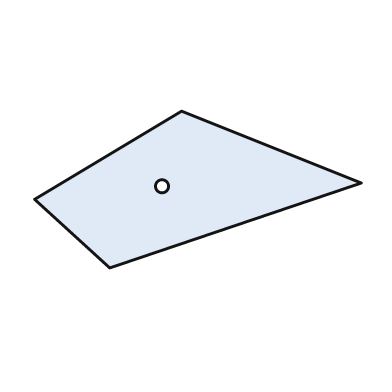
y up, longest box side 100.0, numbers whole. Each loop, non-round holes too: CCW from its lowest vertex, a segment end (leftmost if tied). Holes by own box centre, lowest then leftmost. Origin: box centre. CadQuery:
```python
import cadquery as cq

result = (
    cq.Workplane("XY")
    .moveTo(-27.0, -24.0)
    .lineTo(50.0, 2.0)
    .lineTo(-5.0, 24.0)
    .lineTo(-50.0, -3.0)
    .close()
    .moveTo(-11.0, 1.0)
    .circle(2.0)
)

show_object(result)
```